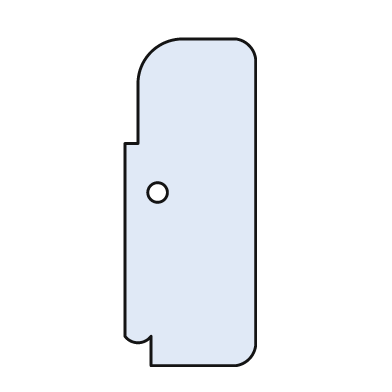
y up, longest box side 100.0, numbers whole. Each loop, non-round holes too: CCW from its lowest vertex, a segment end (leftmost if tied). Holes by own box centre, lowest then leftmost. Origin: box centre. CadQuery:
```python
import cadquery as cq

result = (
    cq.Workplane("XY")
    .moveTo(-12.0, -50.0)
    .lineTo(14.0, -50.0)
    .threePointArc((18.0, -48.0), (20.0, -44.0))
    .lineTo(20.0, 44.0)
    .threePointArc((18.0, 48.0), (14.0, 50.0))
    .lineTo(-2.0, 50.0)
    .threePointArc((-12.0, 46.0), (-16.0, 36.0))
    .lineTo(-16.0, 18.0)
    .lineTo(-20.0, 18.0)
    .lineTo(-20.0, -41.0)
    .threePointArc((-16.0, -43.0), (-12.0, -41.0))
    .close()
    .moveTo(-10.0, 3.0)
    .circle(3.0)
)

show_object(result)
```